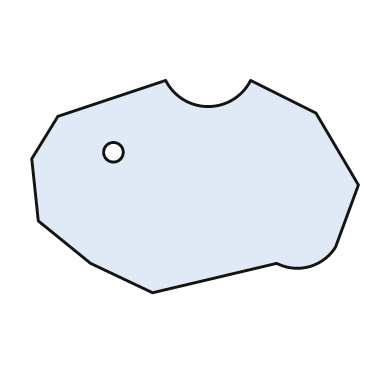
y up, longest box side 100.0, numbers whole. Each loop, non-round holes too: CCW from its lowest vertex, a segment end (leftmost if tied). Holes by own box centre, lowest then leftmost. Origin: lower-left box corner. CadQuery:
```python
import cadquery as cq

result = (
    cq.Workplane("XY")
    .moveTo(37.0, 0.0)
    .lineTo(75.0, 9.0)
    .threePointArc((85.0, 8.0), (93.0, 14.0))
    .lineTo(100.0, 33.0)
    .lineTo(87.0, 55.0)
    .lineTo(67.0, 65.0)
    .threePointArc((54.0, 57.0), (41.0, 65.0))
    .lineTo(8.0, 54.0)
    .lineTo(0.0, 41.0)
    .lineTo(2.0, 22.0)
    .lineTo(18.0, 9.0)
    .close()
    .moveTo(25.0, 43.0)
    .circle(3.0)
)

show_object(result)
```